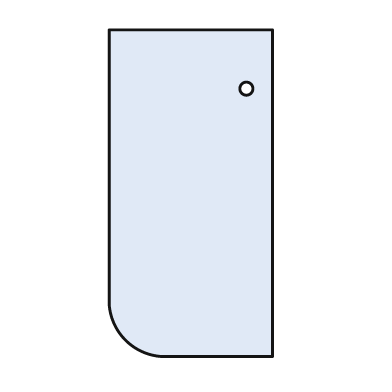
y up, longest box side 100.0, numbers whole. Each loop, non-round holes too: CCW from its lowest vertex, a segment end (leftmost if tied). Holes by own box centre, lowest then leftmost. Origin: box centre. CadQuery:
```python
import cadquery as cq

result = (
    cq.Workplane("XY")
    .moveTo(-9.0, -50.0)
    .lineTo(25.0, -50.0)
    .lineTo(25.0, 50.0)
    .lineTo(-25.0, 50.0)
    .lineTo(-25.0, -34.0)
    .threePointArc((-20.0, -45.0), (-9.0, -50.0))
    .close()
    .moveTo(17.0, 32.0)
    .circle(2.0)
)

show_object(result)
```